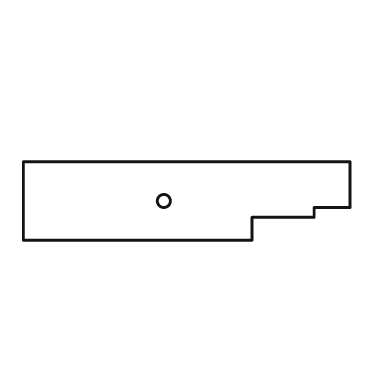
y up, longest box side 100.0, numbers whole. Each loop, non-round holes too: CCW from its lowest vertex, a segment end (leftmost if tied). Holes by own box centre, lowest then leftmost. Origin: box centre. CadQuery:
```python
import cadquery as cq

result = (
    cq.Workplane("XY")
    .moveTo(-50.0, -12.0)
    .lineTo(20.0, -12.0)
    .lineTo(20.0, -5.0)
    .lineTo(39.0, -5.0)
    .lineTo(39.0, -2.0)
    .lineTo(50.0, -2.0)
    .lineTo(50.0, 12.0)
    .lineTo(-50.0, 12.0)
    .close()
    .moveTo(-7.0, 0.0)
    .circle(2.0)
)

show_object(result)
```